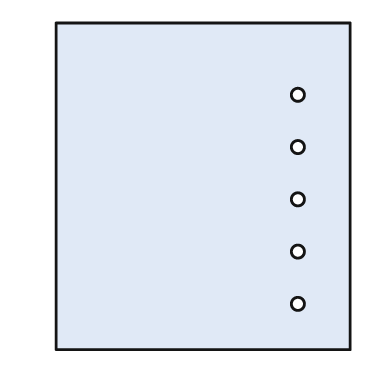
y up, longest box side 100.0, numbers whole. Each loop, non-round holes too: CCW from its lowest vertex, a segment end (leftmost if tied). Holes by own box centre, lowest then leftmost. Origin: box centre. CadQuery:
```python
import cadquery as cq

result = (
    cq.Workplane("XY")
    .moveTo(-45.0, -50.0)
    .lineTo(45.0, -50.0)
    .lineTo(45.0, 50.0)
    .lineTo(-45.0, 50.0)
    .close()
    .moveTo(29.0, -36.0)
    .circle(2.0)
    .moveTo(29.0, -20.0)
    .circle(2.0)
    .moveTo(29.0, -4.0)
    .circle(2.0)
    .moveTo(29.0, 12.0)
    .circle(2.0)
    .moveTo(29.0, 28.0)
    .circle(2.0)
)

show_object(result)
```